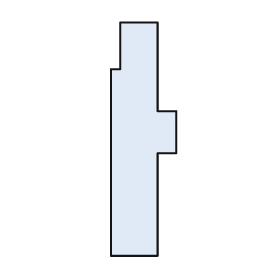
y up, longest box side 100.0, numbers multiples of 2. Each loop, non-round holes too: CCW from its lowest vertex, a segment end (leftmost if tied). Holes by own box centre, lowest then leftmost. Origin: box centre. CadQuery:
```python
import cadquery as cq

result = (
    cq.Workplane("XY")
    .moveTo(-14.0, -50.0)
    .lineTo(6.0, -50.0)
    .lineTo(6.0, -6.0)
    .lineTo(14.0, -6.0)
    .lineTo(14.0, 12.0)
    .lineTo(6.0, 12.0)
    .lineTo(6.0, 50.0)
    .lineTo(-10.0, 50.0)
    .lineTo(-10.0, 30.0)
    .lineTo(-14.0, 30.0)
    .close()
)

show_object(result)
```